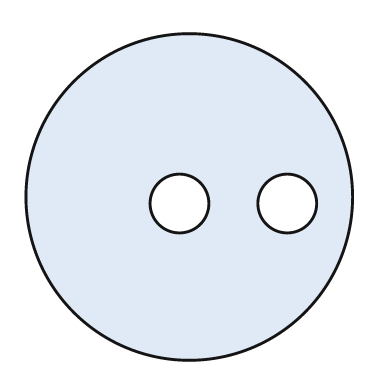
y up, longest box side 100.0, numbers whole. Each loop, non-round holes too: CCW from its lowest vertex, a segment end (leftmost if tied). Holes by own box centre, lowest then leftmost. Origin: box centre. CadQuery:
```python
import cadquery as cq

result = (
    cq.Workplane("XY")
    .moveTo(0.0, 0.0)
    .circle(50.0)
    .moveTo(-3.0, -2.0)
    .circle(9.0)
    .moveTo(30.0, -2.0)
    .circle(9.0)
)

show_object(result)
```